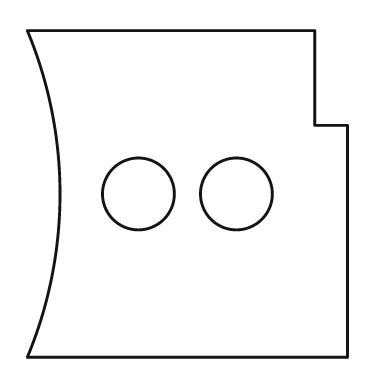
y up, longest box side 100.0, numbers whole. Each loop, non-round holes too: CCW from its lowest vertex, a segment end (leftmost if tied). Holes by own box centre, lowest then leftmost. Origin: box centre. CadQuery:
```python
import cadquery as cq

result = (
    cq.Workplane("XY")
    .moveTo(-49.0, -50.0)
    .lineTo(49.0, -50.0)
    .lineTo(49.0, 21.0)
    .lineTo(39.0, 21.0)
    .lineTo(39.0, 50.0)
    .lineTo(-49.0, 50.0)
    .threePointArc((-39.0, 0.0), (-49.0, -50.0))
    .close()
    .moveTo(-15.0, 0.0)
    .circle(11.0)
    .moveTo(15.0, 0.0)
    .circle(11.0)
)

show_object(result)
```